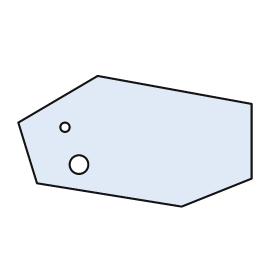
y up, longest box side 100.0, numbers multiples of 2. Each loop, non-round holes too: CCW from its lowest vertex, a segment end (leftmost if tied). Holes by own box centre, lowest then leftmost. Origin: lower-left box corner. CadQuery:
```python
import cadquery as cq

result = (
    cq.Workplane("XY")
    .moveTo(70.0, 0.0)
    .lineTo(100.0, 12.0)
    .lineTo(100.0, 44.0)
    .lineTo(34.0, 56.0)
    .lineTo(0.0, 36.0)
    .lineTo(8.0, 10.0)
    .close()
    .moveTo(26.0, 18.0)
    .circle(4.0)
    .moveTo(20.0, 34.0)
    .circle(2.0)
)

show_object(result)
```